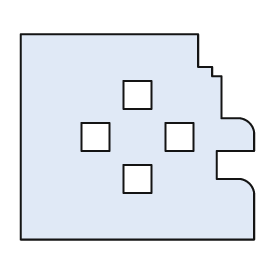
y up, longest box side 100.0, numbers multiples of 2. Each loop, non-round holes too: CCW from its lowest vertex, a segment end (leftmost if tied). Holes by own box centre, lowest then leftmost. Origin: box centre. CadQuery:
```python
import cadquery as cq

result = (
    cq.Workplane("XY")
    .moveTo(-50.0, -44.0)
    .lineTo(50.0, -44.0)
    .lineTo(50.0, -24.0)
    .threePointArc((48.0, -20.0), (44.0, -18.0))
    .lineTo(34.0, -18.0)
    .lineTo(34.0, -6.0)
    .lineTo(50.0, -6.0)
    .lineTo(50.0, 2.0)
    .threePointArc((48.0, 6.0), (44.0, 8.0))
    .lineTo(36.0, 8.0)
    .lineTo(36.0, 26.0)
    .lineTo(32.0, 26.0)
    .lineTo(32.0, 30.0)
    .lineTo(26.0, 30.0)
    .lineTo(26.0, 44.0)
    .lineTo(-50.0, 44.0)
    .close()
    .moveTo(-6.0, -24.0)
    .lineTo(6.0, -24.0)
    .lineTo(6.0, -12.0)
    .lineTo(-6.0, -12.0)
    .close()
    .moveTo(-24.0, -6.0)
    .lineTo(-12.0, -6.0)
    .lineTo(-12.0, 6.0)
    .lineTo(-24.0, 6.0)
    .close()
    .moveTo(12.0, -6.0)
    .lineTo(24.0, -6.0)
    .lineTo(24.0, 6.0)
    .lineTo(12.0, 6.0)
    .close()
    .moveTo(-6.0, 12.0)
    .lineTo(6.0, 12.0)
    .lineTo(6.0, 24.0)
    .lineTo(-6.0, 24.0)
    .close()
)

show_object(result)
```